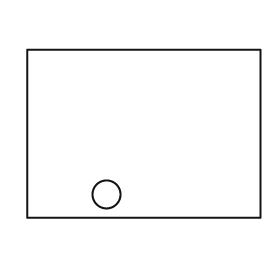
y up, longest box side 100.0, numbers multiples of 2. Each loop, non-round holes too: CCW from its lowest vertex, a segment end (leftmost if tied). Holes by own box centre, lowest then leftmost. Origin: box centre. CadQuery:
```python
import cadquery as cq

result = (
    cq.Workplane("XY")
    .moveTo(-50.0, -36.0)
    .lineTo(50.0, -36.0)
    .lineTo(50.0, 36.0)
    .lineTo(-50.0, 36.0)
    .close()
    .moveTo(-16.0, -26.0)
    .circle(6.0)
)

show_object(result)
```